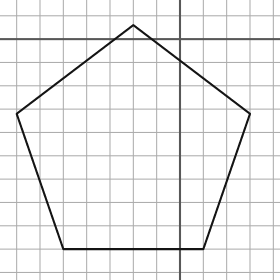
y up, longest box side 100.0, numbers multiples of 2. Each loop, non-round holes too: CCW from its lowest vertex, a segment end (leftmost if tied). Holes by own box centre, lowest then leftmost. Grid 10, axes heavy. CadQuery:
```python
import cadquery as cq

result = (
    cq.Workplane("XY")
    .moveTo(-50.0, -90.0)
    .lineTo(10.0, -90.0)
    .lineTo(30.0, -32.0)
    .lineTo(-20.0, 6.0)
    .lineTo(-70.0, -32.0)
    .close()
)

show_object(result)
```